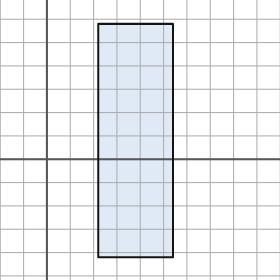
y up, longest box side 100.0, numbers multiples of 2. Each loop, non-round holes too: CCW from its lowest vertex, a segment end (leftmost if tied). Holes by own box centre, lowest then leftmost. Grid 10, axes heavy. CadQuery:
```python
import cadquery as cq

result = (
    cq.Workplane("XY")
    .moveTo(22.0, -42.0)
    .lineTo(54.0, -42.0)
    .lineTo(54.0, 58.0)
    .lineTo(22.0, 58.0)
    .close()
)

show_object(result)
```